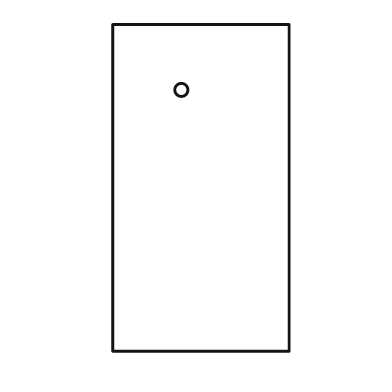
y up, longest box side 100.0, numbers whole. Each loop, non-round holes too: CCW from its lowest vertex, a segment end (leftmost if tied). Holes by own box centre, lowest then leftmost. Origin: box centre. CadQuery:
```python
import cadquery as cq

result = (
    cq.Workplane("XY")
    .moveTo(-27.0, -50.0)
    .lineTo(27.0, -50.0)
    .lineTo(27.0, 50.0)
    .lineTo(-27.0, 50.0)
    .close()
    .moveTo(-6.0, 30.0)
    .circle(2.0)
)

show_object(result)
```